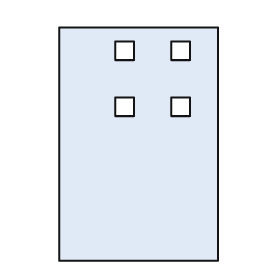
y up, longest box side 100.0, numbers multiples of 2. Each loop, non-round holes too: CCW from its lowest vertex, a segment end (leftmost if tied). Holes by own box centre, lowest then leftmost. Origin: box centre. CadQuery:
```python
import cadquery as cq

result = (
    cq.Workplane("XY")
    .moveTo(-34.0, -50.0)
    .lineTo(34.0, -50.0)
    .lineTo(34.0, 50.0)
    .lineTo(-34.0, 50.0)
    .close()
    .moveTo(-10.0, 12.0)
    .lineTo(-2.0, 12.0)
    .lineTo(-2.0, 20.0)
    .lineTo(-10.0, 20.0)
    .close()
    .moveTo(14.0, 12.0)
    .lineTo(22.0, 12.0)
    .lineTo(22.0, 20.0)
    .lineTo(14.0, 20.0)
    .close()
    .moveTo(-10.0, 36.0)
    .lineTo(-2.0, 36.0)
    .lineTo(-2.0, 44.0)
    .lineTo(-10.0, 44.0)
    .close()
    .moveTo(14.0, 36.0)
    .lineTo(22.0, 36.0)
    .lineTo(22.0, 44.0)
    .lineTo(14.0, 44.0)
    .close()
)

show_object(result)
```